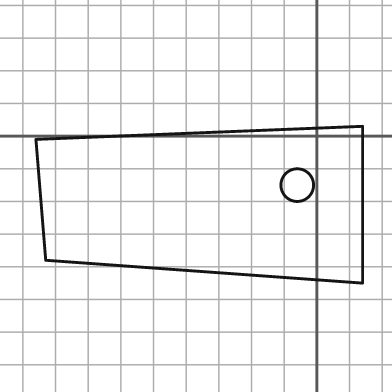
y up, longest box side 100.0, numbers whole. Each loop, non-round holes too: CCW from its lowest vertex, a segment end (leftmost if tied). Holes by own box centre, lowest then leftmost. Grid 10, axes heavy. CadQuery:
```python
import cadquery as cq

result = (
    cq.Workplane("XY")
    .moveTo(14.0, -45.0)
    .lineTo(14.0, 3.0)
    .lineTo(-86.0, -1.0)
    .lineTo(-83.0, -38.0)
    .close()
    .moveTo(-6.0, -15.0)
    .circle(5.0)
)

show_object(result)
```